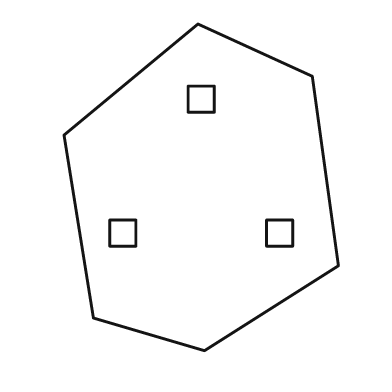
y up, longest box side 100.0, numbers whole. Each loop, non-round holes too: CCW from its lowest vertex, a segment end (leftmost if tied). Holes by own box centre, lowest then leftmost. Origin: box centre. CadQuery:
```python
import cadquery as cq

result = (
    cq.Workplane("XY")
    .moveTo(1.0, -50.0)
    .lineTo(42.0, -24.0)
    .lineTo(34.0, 34.0)
    .lineTo(-1.0, 50.0)
    .lineTo(-42.0, 16.0)
    .lineTo(-33.0, -40.0)
    .close()
    .moveTo(-28.0, -18.0)
    .lineTo(-20.0, -18.0)
    .lineTo(-20.0, -10.0)
    .lineTo(-28.0, -10.0)
    .close()
    .moveTo(20.0, -18.0)
    .lineTo(28.0, -18.0)
    .lineTo(28.0, -10.0)
    .lineTo(20.0, -10.0)
    .close()
    .moveTo(-4.0, 23.0)
    .lineTo(4.0, 23.0)
    .lineTo(4.0, 31.0)
    .lineTo(-4.0, 31.0)
    .close()
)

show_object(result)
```